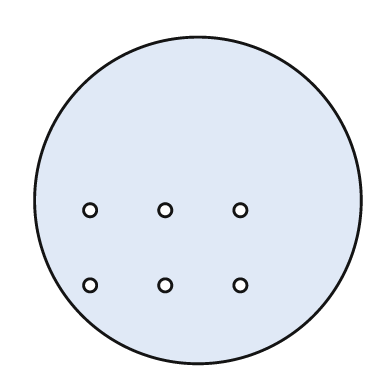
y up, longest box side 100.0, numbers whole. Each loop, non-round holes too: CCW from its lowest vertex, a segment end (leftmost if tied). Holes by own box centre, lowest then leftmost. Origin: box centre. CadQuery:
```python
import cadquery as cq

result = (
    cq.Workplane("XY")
    .moveTo(0.0, 0.0)
    .circle(50.0)
    .moveTo(-33.0, -26.0)
    .circle(2.0)
    .moveTo(-10.0, -26.0)
    .circle(2.0)
    .moveTo(13.0, -26.0)
    .circle(2.0)
    .moveTo(-33.0, -3.0)
    .circle(2.0)
    .moveTo(-10.0, -3.0)
    .circle(2.0)
    .moveTo(13.0, -3.0)
    .circle(2.0)
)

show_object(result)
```